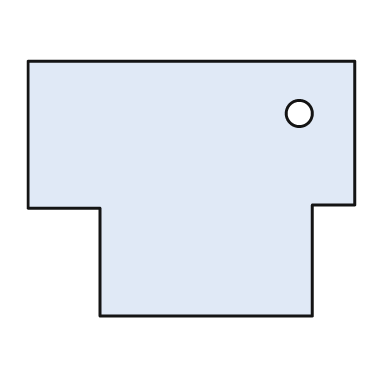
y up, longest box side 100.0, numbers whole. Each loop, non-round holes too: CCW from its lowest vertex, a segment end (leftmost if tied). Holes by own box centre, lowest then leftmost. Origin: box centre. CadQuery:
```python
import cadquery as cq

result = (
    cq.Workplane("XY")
    .moveTo(-28.0, -39.0)
    .lineTo(37.0, -39.0)
    .lineTo(37.0, -5.0)
    .lineTo(50.0, -5.0)
    .lineTo(50.0, 39.0)
    .lineTo(-50.0, 39.0)
    .lineTo(-50.0, -6.0)
    .lineTo(-28.0, -6.0)
    .close()
    .moveTo(33.0, 23.0)
    .circle(4.0)
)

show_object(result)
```